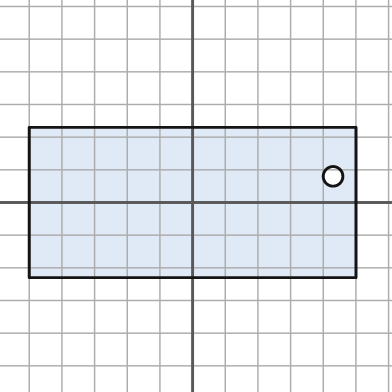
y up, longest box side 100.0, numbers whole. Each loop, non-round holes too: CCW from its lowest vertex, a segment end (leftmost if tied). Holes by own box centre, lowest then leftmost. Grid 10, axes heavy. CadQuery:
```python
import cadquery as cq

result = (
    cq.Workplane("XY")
    .moveTo(-50.0, -23.0)
    .lineTo(50.0, -23.0)
    .lineTo(50.0, 23.0)
    .lineTo(-50.0, 23.0)
    .close()
    .moveTo(43.0, 8.0)
    .circle(3.0)
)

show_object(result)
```